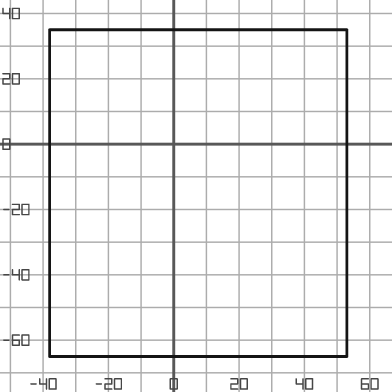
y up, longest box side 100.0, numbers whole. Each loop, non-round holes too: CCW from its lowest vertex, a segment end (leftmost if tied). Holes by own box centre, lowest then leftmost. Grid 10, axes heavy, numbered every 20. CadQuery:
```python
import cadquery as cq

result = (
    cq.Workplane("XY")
    .moveTo(-38.0, -65.0)
    .lineTo(53.0, -65.0)
    .lineTo(53.0, 35.0)
    .lineTo(-38.0, 35.0)
    .close()
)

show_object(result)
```